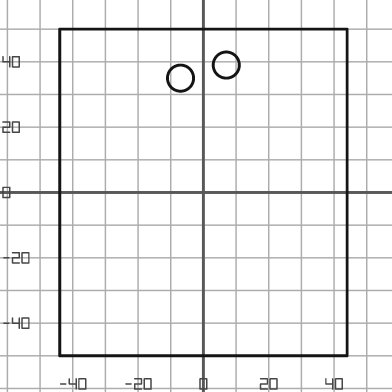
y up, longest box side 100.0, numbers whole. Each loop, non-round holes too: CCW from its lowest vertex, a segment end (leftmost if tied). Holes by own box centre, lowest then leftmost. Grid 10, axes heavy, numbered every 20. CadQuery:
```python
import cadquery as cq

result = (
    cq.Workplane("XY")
    .moveTo(-44.0, -50.0)
    .lineTo(44.0, -50.0)
    .lineTo(44.0, 50.0)
    .lineTo(-44.0, 50.0)
    .close()
    .moveTo(-7.0, 35.0)
    .circle(4.0)
    .moveTo(7.0, 39.0)
    .circle(4.0)
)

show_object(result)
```